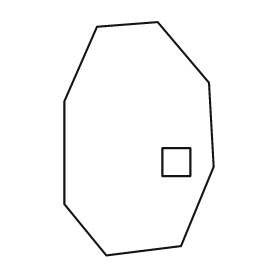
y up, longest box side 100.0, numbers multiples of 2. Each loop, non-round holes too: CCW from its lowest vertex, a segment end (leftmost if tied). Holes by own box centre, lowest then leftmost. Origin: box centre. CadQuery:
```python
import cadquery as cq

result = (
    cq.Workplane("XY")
    .moveTo(-14.0, -50.0)
    .lineTo(18.0, -46.0)
    .lineTo(32.0, -12.0)
    .lineTo(30.0, 24.0)
    .lineTo(8.0, 50.0)
    .lineTo(-18.0, 48.0)
    .lineTo(-32.0, 16.0)
    .lineTo(-32.0, -28.0)
    .close()
    .moveTo(10.0, -16.0)
    .lineTo(22.0, -16.0)
    .lineTo(22.0, -4.0)
    .lineTo(10.0, -4.0)
    .close()
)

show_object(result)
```